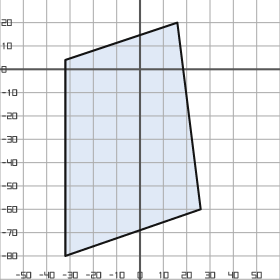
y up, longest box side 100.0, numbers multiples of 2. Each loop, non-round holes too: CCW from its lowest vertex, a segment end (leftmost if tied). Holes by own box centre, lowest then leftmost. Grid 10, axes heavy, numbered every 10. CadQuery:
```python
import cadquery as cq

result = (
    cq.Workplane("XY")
    .moveTo(-32.0, -80.0)
    .lineTo(26.0, -60.0)
    .lineTo(16.0, 20.0)
    .lineTo(-32.0, 4.0)
    .close()
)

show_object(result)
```